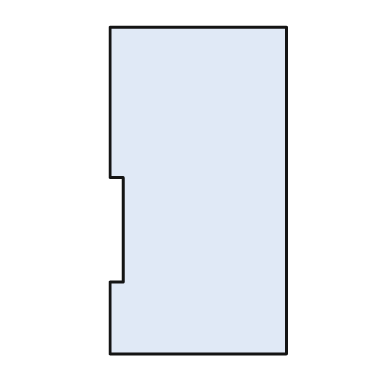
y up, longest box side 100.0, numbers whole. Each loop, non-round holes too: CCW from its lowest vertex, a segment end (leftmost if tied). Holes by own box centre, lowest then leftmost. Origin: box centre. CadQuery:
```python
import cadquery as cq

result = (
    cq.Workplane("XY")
    .moveTo(-27.0, -50.0)
    .lineTo(27.0, -50.0)
    .lineTo(27.0, 50.0)
    .lineTo(-27.0, 50.0)
    .lineTo(-27.0, 4.0)
    .lineTo(-23.0, 4.0)
    .lineTo(-23.0, -28.0)
    .lineTo(-27.0, -28.0)
    .close()
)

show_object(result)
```